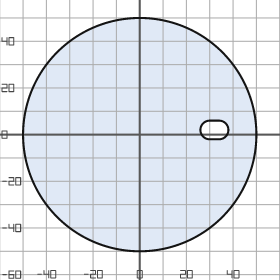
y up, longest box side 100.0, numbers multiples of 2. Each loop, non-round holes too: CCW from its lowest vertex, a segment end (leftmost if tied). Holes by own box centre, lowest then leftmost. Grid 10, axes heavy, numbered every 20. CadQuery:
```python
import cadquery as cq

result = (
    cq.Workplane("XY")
    .moveTo(0.0, 0.0)
    .circle(50.0)
    .moveTo(30.0, -2.0)
    .lineTo(34.0, -2.0)
    .threePointArc((38.0, 2.0), (34.0, 6.0))
    .lineTo(30.0, 6.0)
    .threePointArc((26.0, 2.0), (30.0, -2.0))
    .close()
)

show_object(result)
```